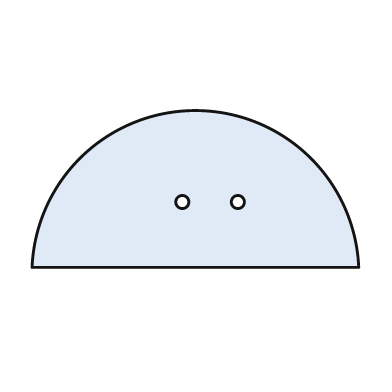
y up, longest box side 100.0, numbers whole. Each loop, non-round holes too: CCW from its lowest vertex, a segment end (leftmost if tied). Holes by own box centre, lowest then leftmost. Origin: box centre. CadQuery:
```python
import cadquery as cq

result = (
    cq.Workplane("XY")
    .moveTo(-50.0, -24.0)
    .lineTo(50.0, -24.0)
    .threePointArc((0.0, 24.0), (-50.0, -24.0))
    .close()
    .moveTo(-4.0, -4.0)
    .circle(2.0)
    .moveTo(13.0, -4.0)
    .circle(2.0)
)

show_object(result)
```